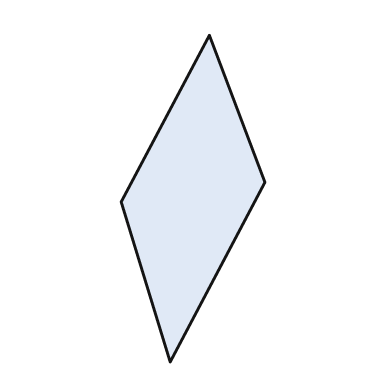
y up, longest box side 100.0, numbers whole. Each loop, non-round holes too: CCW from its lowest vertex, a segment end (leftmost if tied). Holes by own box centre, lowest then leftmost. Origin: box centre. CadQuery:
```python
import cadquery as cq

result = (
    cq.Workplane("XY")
    .moveTo(-7.0, -50.0)
    .lineTo(22.0, 5.0)
    .lineTo(5.0, 50.0)
    .lineTo(-22.0, -1.0)
    .close()
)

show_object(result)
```